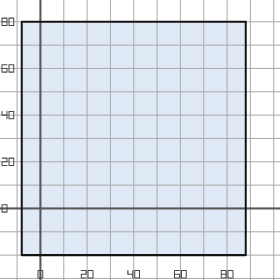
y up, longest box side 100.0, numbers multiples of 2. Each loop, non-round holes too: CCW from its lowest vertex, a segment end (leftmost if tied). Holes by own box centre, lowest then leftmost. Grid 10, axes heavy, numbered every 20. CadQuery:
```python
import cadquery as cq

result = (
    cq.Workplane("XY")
    .moveTo(-8.0, -20.0)
    .lineTo(88.0, -20.0)
    .lineTo(88.0, 80.0)
    .lineTo(-8.0, 80.0)
    .close()
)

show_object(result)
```